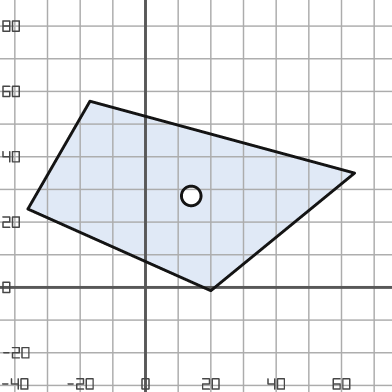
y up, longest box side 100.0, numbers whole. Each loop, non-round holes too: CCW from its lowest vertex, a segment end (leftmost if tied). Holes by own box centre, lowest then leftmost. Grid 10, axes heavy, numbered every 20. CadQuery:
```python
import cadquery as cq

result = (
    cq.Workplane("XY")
    .moveTo(20.0, -1.0)
    .lineTo(64.0, 35.0)
    .lineTo(-17.0, 57.0)
    .lineTo(-36.0, 24.0)
    .close()
    .moveTo(14.0, 28.0)
    .circle(3.0)
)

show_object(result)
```